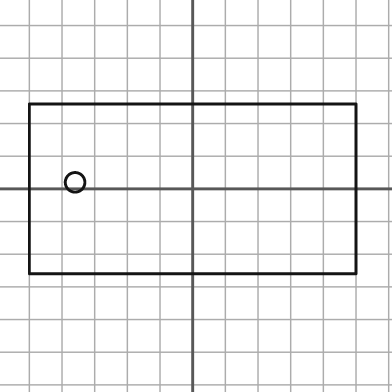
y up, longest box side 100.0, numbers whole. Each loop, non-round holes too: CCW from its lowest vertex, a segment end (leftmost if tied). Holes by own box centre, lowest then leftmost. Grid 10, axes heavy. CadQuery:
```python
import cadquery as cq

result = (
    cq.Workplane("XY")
    .moveTo(-50.0, -26.0)
    .lineTo(50.0, -26.0)
    .lineTo(50.0, 26.0)
    .lineTo(-50.0, 26.0)
    .close()
    .moveTo(-36.0, 2.0)
    .circle(3.0)
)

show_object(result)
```